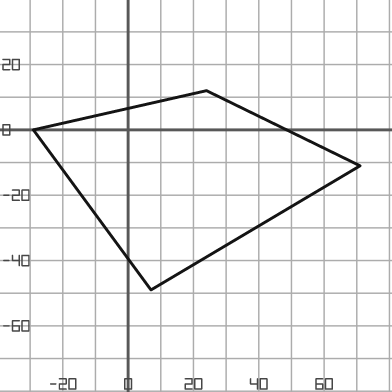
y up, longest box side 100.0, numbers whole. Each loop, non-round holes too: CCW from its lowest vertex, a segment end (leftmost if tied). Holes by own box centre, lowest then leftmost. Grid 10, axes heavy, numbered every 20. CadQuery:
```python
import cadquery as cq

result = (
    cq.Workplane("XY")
    .moveTo(7.0, -49.0)
    .lineTo(71.0, -11.0)
    .lineTo(24.0, 12.0)
    .lineTo(-29.0, 0.0)
    .close()
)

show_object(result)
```